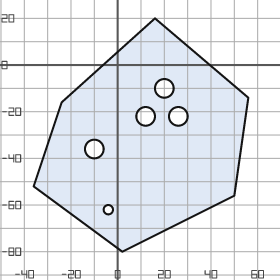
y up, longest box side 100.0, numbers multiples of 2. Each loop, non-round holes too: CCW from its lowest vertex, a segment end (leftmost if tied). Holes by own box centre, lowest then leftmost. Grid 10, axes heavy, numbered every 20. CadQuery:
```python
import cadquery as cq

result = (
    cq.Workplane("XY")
    .moveTo(2.0, -80.0)
    .lineTo(50.0, -56.0)
    .lineTo(56.0, -14.0)
    .lineTo(16.0, 20.0)
    .lineTo(-24.0, -16.0)
    .lineTo(-36.0, -52.0)
    .close()
    .moveTo(-4.0, -62.0)
    .circle(2.0)
    .moveTo(-10.0, -36.0)
    .circle(4.0)
    .moveTo(12.0, -22.0)
    .circle(4.0)
    .moveTo(26.0, -22.0)
    .circle(4.0)
    .moveTo(20.0, -10.0)
    .circle(4.0)
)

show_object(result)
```